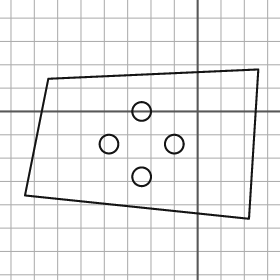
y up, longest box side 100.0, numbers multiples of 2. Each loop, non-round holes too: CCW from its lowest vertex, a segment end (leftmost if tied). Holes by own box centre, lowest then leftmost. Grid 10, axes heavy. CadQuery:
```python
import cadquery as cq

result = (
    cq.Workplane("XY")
    .moveTo(22.0, -46.0)
    .lineTo(26.0, 18.0)
    .lineTo(-64.0, 14.0)
    .lineTo(-74.0, -36.0)
    .close()
    .moveTo(-24.0, -28.0)
    .circle(4.0)
    .moveTo(-38.0, -14.0)
    .circle(4.0)
    .moveTo(-10.0, -14.0)
    .circle(4.0)
    .moveTo(-24.0, 0.0)
    .circle(4.0)
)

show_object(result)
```